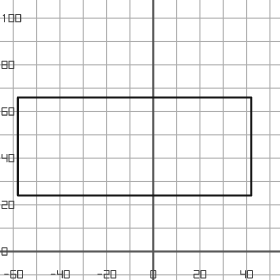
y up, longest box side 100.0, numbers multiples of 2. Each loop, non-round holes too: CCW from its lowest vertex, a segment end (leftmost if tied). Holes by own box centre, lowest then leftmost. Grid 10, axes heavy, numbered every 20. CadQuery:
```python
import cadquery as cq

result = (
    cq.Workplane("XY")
    .moveTo(-58.0, 24.0)
    .lineTo(42.0, 24.0)
    .lineTo(42.0, 66.0)
    .lineTo(-58.0, 66.0)
    .close()
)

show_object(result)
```